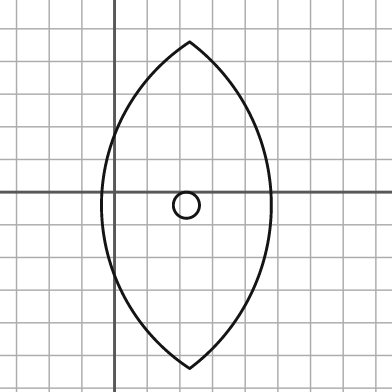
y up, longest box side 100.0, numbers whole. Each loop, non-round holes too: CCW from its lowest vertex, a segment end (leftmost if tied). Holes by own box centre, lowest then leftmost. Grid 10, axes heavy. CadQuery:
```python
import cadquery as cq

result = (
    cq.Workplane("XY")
    .moveTo(23.0, -54.0)
    .threePointArc((48.0, -4.0), (23.0, 46.0))
    .threePointArc((-4.0, -4.0), (23.0, -54.0))
    .close()
    .moveTo(22.0, -4.0)
    .circle(4.0)
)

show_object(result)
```